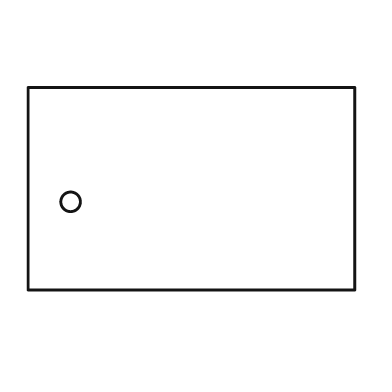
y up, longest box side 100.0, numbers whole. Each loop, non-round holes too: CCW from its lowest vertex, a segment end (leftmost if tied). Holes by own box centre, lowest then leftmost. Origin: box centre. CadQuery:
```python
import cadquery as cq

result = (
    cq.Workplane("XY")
    .moveTo(-50.0, -31.0)
    .lineTo(50.0, -31.0)
    .lineTo(50.0, 31.0)
    .lineTo(-50.0, 31.0)
    .close()
    .moveTo(-37.0, -4.0)
    .circle(3.0)
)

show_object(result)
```